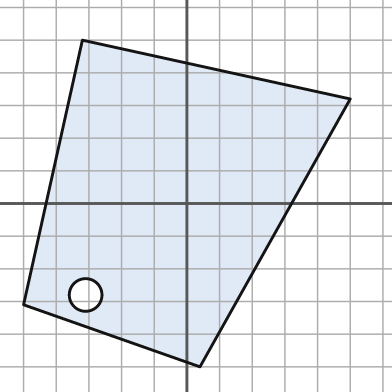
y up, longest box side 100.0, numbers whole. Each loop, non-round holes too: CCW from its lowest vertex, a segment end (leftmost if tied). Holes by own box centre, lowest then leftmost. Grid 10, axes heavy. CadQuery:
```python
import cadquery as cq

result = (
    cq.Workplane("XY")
    .moveTo(4.0, -50.0)
    .lineTo(50.0, 32.0)
    .lineTo(-32.0, 50.0)
    .lineTo(-50.0, -31.0)
    .close()
    .moveTo(-31.0, -28.0)
    .circle(5.0)
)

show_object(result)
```